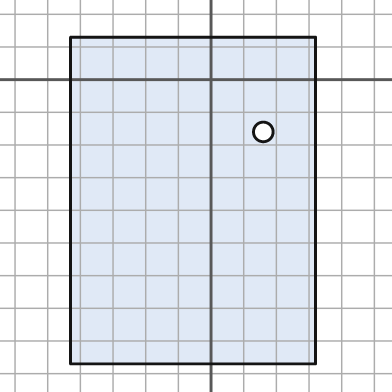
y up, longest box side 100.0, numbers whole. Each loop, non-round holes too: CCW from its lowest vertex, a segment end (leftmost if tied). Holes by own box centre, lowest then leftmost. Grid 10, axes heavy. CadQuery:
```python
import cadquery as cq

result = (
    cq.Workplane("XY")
    .moveTo(-43.0, -87.0)
    .lineTo(32.0, -87.0)
    .lineTo(32.0, 13.0)
    .lineTo(-43.0, 13.0)
    .close()
    .moveTo(16.0, -16.0)
    .circle(3.0)
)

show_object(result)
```